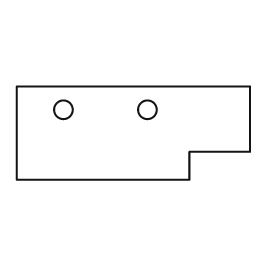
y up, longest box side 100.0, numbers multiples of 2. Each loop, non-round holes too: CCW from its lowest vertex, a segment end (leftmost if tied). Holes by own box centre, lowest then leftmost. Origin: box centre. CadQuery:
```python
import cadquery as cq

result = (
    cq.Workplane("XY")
    .moveTo(-50.0, -20.0)
    .lineTo(24.0, -20.0)
    .lineTo(24.0, -8.0)
    .lineTo(50.0, -8.0)
    .lineTo(50.0, 20.0)
    .lineTo(-50.0, 20.0)
    .close()
    .moveTo(-30.0, 10.0)
    .circle(4.0)
    .moveTo(6.0, 10.0)
    .circle(4.0)
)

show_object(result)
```